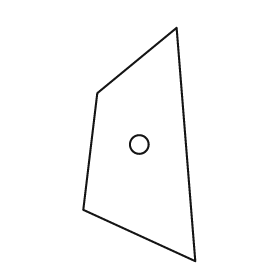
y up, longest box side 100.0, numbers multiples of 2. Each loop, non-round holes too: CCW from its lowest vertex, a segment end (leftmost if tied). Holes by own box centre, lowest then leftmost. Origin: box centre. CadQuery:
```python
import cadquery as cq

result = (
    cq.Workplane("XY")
    .moveTo(24.0, -50.0)
    .lineTo(16.0, 50.0)
    .lineTo(-18.0, 22.0)
    .lineTo(-24.0, -28.0)
    .close()
    .moveTo(0.0, 0.0)
    .circle(4.0)
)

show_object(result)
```